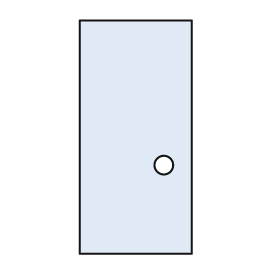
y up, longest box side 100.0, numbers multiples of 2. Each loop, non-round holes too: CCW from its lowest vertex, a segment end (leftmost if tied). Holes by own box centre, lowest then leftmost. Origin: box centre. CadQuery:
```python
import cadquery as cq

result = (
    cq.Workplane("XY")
    .moveTo(-24.0, -50.0)
    .lineTo(24.0, -50.0)
    .lineTo(24.0, 50.0)
    .lineTo(-24.0, 50.0)
    .close()
    .moveTo(12.0, -12.0)
    .circle(4.0)
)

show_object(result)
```